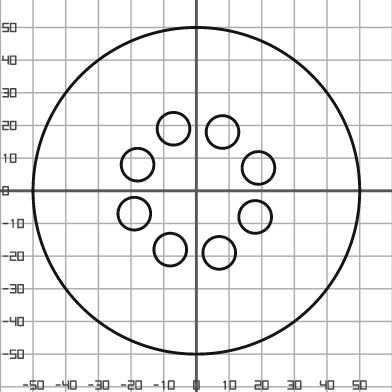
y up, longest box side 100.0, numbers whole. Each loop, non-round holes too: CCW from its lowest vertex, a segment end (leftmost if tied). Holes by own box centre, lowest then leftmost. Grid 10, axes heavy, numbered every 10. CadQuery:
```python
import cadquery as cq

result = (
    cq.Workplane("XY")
    .moveTo(0.0, 0.0)
    .circle(50.0)
    .moveTo(7.0, -19.0)
    .circle(5.0)
    .moveTo(-8.0, -18.0)
    .circle(5.0)
    .moveTo(18.0, -8.0)
    .circle(5.0)
    .moveTo(-19.0, -7.0)
    .circle(5.0)
    .moveTo(19.0, 7.0)
    .circle(5.0)
    .moveTo(-18.0, 8.0)
    .circle(5.0)
    .moveTo(8.0, 18.0)
    .circle(5.0)
    .moveTo(-7.0, 19.0)
    .circle(5.0)
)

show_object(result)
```